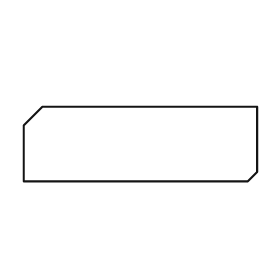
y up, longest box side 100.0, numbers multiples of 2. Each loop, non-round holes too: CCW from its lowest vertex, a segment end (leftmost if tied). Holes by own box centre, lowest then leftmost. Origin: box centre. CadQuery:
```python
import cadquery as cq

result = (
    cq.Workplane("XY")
    .moveTo(-50.0, -16.0)
    .lineTo(46.0, -16.0)
    .lineTo(50.0, -12.0)
    .lineTo(50.0, 16.0)
    .lineTo(-42.0, 16.0)
    .lineTo(-50.0, 8.0)
    .close()
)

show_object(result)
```